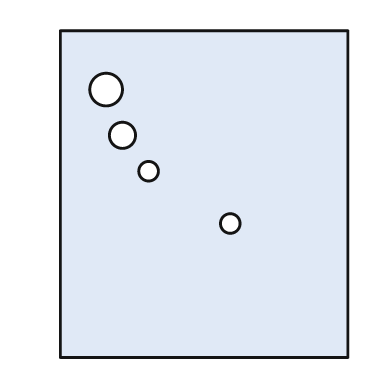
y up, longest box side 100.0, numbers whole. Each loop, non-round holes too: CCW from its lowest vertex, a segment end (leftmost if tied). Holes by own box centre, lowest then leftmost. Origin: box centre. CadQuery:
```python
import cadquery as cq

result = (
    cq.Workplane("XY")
    .moveTo(-44.0, -50.0)
    .lineTo(44.0, -50.0)
    .lineTo(44.0, 50.0)
    .lineTo(-44.0, 50.0)
    .close()
    .moveTo(8.0, -9.0)
    .circle(3.0)
    .moveTo(-17.0, 7.0)
    .circle(3.0)
    .moveTo(-25.0, 18.0)
    .circle(4.0)
    .moveTo(-30.0, 32.0)
    .circle(5.0)
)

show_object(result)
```